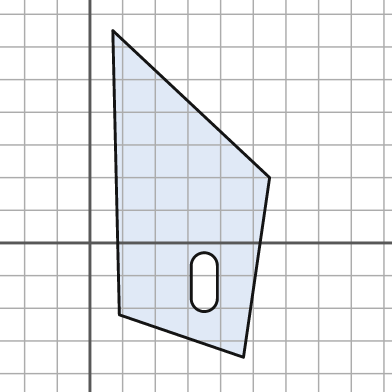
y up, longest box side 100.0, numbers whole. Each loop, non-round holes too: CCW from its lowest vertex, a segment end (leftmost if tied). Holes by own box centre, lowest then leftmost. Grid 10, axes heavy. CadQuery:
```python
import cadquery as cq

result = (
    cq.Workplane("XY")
    .moveTo(47.0, -35.0)
    .lineTo(55.0, 20.0)
    .lineTo(7.0, 65.0)
    .lineTo(9.0, -22.0)
    .close()
    .moveTo(31.0, -17.0)
    .threePointArc((35.0, -21.0), (39.0, -17.0))
    .lineTo(39.0, -7.0)
    .threePointArc((35.0, -3.0), (31.0, -7.0))
    .close()
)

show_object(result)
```